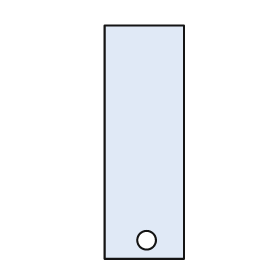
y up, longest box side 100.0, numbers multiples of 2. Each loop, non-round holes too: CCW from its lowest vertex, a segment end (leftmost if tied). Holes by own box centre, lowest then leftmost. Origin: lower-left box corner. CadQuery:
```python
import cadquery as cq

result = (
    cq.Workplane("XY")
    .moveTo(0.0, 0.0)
    .lineTo(34.0, 0.0)
    .lineTo(34.0, 100.0)
    .lineTo(0.0, 100.0)
    .close()
    .moveTo(18.0, 8.0)
    .circle(4.0)
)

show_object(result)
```